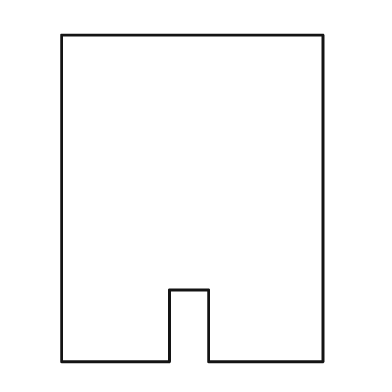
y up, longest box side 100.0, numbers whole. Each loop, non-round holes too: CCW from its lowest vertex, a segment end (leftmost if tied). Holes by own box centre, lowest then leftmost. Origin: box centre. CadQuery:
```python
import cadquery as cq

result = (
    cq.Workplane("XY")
    .moveTo(-40.0, -50.0)
    .lineTo(-7.0, -50.0)
    .lineTo(-7.0, -28.0)
    .lineTo(5.0, -28.0)
    .lineTo(5.0, -50.0)
    .lineTo(40.0, -50.0)
    .lineTo(40.0, 50.0)
    .lineTo(-40.0, 50.0)
    .close()
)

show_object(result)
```